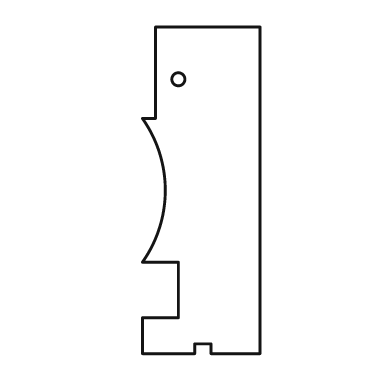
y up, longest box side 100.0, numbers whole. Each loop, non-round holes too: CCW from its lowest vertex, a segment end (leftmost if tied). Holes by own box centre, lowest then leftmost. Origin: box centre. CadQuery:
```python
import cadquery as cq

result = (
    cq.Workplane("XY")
    .moveTo(-18.0, -50.0)
    .lineTo(-2.0, -50.0)
    .lineTo(-2.0, -47.0)
    .lineTo(3.0, -47.0)
    .lineTo(3.0, -50.0)
    .lineTo(18.0, -50.0)
    .lineTo(18.0, 50.0)
    .lineTo(-14.0, 50.0)
    .lineTo(-14.0, 22.0)
    .lineTo(-18.0, 22.0)
    .threePointArc((-11.0, 0.0), (-18.0, -22.0))
    .lineTo(-7.0, -22.0)
    .lineTo(-7.0, -39.0)
    .lineTo(-18.0, -39.0)
    .close()
    .moveTo(-7.0, 34.0)
    .circle(2.0)
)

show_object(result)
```